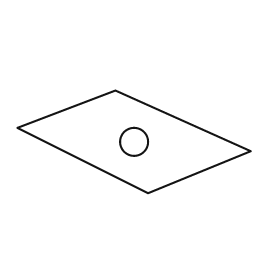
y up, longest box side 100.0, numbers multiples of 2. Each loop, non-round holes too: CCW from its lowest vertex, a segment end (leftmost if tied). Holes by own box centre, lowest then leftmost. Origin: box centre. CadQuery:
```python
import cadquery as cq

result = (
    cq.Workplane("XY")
    .moveTo(6.0, -22.0)
    .lineTo(50.0, -4.0)
    .lineTo(-8.0, 22.0)
    .lineTo(-50.0, 6.0)
    .close()
    .moveTo(0.0, 0.0)
    .circle(6.0)
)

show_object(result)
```